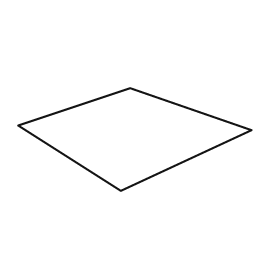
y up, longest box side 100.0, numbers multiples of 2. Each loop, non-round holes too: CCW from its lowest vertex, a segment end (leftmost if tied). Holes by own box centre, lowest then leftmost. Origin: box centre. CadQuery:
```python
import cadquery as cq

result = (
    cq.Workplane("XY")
    .moveTo(-6.0, -22.0)
    .lineTo(50.0, 4.0)
    .lineTo(-2.0, 22.0)
    .lineTo(-50.0, 6.0)
    .close()
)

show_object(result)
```